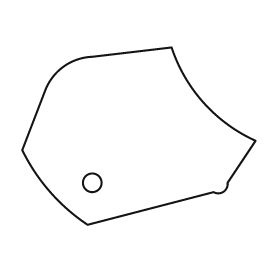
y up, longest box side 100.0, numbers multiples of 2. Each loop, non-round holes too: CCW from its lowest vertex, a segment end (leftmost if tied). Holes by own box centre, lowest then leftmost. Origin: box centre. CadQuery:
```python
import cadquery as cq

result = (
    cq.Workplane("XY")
    .moveTo(-22.0, -38.0)
    .lineTo(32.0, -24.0)
    .threePointArc((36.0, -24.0), (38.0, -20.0))
    .lineTo(50.0, -2.0)
    .threePointArc((28.0, 14.0), (14.0, 38.0))
    .lineTo(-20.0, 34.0)
    .threePointArc((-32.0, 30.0), (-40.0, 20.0))
    .lineTo(-50.0, -6.0)
    .threePointArc((-38.0, -24.0), (-22.0, -38.0))
    .close()
    .moveTo(-20.0, -20.0)
    .circle(4.0)
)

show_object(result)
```